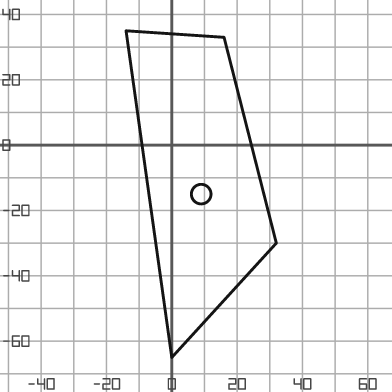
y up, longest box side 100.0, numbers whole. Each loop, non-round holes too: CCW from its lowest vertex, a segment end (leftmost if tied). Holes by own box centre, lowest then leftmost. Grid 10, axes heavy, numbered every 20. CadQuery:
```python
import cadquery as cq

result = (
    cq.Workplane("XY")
    .moveTo(0.0, -65.0)
    .lineTo(32.0, -30.0)
    .lineTo(16.0, 33.0)
    .lineTo(-14.0, 35.0)
    .close()
    .moveTo(9.0, -15.0)
    .circle(3.0)
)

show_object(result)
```